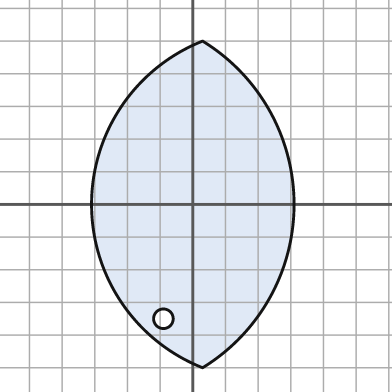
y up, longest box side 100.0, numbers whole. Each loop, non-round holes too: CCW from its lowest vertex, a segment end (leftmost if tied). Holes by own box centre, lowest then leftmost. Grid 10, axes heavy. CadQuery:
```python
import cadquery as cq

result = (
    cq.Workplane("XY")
    .moveTo(3.0, -50.0)
    .threePointArc((31.0, 0.0), (3.0, 50.0))
    .threePointArc((-31.0, 0.0), (3.0, -50.0))
    .close()
    .moveTo(-9.0, -35.0)
    .circle(3.0)
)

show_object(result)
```